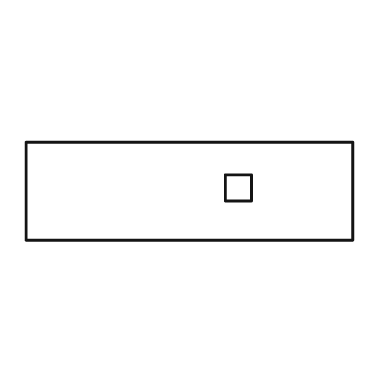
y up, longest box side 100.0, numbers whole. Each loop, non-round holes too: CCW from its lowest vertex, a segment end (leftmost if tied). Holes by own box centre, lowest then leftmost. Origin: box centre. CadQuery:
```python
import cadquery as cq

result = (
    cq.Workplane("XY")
    .moveTo(-50.0, -15.0)
    .lineTo(50.0, -15.0)
    .lineTo(50.0, 15.0)
    .lineTo(-50.0, 15.0)
    .close()
    .moveTo(11.0, -3.0)
    .lineTo(19.0, -3.0)
    .lineTo(19.0, 5.0)
    .lineTo(11.0, 5.0)
    .close()
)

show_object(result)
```